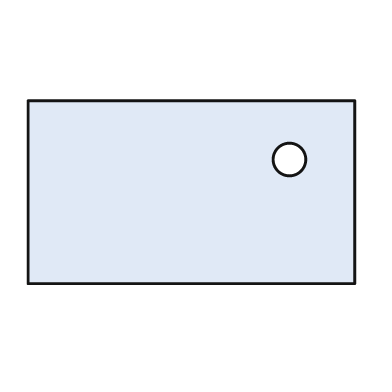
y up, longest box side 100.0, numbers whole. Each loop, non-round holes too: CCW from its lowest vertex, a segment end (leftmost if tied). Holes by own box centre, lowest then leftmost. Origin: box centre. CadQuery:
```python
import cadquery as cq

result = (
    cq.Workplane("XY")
    .moveTo(-50.0, -28.0)
    .lineTo(50.0, -28.0)
    .lineTo(50.0, 28.0)
    .lineTo(-50.0, 28.0)
    .close()
    .moveTo(30.0, 10.0)
    .circle(5.0)
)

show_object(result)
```